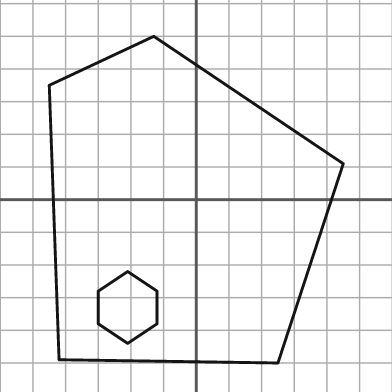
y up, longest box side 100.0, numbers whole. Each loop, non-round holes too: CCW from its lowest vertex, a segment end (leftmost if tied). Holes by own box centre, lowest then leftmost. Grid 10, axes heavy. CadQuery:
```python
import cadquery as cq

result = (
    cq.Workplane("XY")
    .moveTo(25.0, -50.0)
    .lineTo(45.0, 11.0)
    .lineTo(-13.0, 50.0)
    .lineTo(-45.0, 35.0)
    .lineTo(-42.0, -49.0)
    .close()
    .moveTo(-21.0, -44.0)
    .lineTo(-12.0, -38.0)
    .lineTo(-12.0, -28.0)
    .lineTo(-21.0, -22.0)
    .lineTo(-30.0, -28.0)
    .lineTo(-30.0, -38.0)
    .close()
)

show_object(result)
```